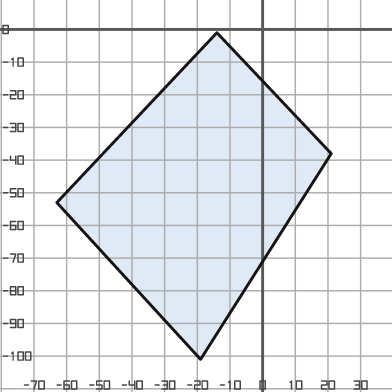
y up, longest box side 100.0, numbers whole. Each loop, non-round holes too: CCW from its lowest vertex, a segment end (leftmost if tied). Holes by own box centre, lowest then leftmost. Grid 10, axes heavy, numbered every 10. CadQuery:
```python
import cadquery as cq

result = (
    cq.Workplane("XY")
    .moveTo(-19.0, -101.0)
    .lineTo(21.0, -38.0)
    .lineTo(-14.0, -1.0)
    .lineTo(-63.0, -53.0)
    .close()
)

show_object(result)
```